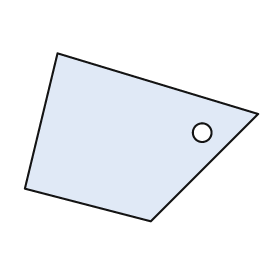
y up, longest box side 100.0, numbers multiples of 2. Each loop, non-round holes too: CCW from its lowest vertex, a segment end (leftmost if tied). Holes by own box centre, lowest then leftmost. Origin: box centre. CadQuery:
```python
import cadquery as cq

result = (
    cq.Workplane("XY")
    .moveTo(4.0, -36.0)
    .lineTo(50.0, 10.0)
    .lineTo(-36.0, 36.0)
    .lineTo(-50.0, -22.0)
    .close()
    .moveTo(26.0, 2.0)
    .circle(4.0)
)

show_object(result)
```